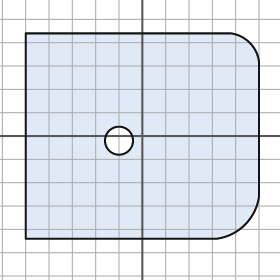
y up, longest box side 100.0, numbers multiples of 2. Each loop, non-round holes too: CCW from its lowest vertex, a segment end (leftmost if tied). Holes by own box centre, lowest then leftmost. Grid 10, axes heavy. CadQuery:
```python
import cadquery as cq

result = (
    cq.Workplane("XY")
    .moveTo(-50.0, -44.0)
    .lineTo(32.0, -44.0)
    .threePointArc((44.0, -38.0), (50.0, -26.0))
    .lineTo(50.0, 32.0)
    .threePointArc((46.0, 40.0), (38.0, 44.0))
    .lineTo(-50.0, 44.0)
    .close()
    .moveTo(-10.0, -2.0)
    .circle(6.0)
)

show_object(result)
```